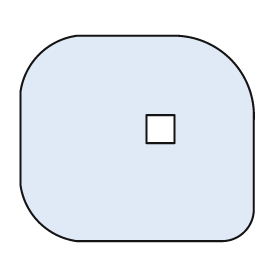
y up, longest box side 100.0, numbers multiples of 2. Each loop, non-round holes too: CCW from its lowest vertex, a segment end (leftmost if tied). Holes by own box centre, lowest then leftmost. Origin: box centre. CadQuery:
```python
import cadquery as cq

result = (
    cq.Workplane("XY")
    .moveTo(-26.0, -44.0)
    .lineTo(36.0, -44.0)
    .threePointArc((46.0, -40.0), (50.0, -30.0))
    .lineTo(50.0, 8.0)
    .threePointArc((40.0, 34.0), (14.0, 44.0))
    .lineTo(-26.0, 44.0)
    .threePointArc((-42.0, 36.0), (-50.0, 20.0))
    .lineTo(-50.0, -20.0)
    .threePointArc((-42.0, -36.0), (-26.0, -44.0))
    .close()
    .moveTo(4.0, -2.0)
    .lineTo(16.0, -2.0)
    .lineTo(16.0, 10.0)
    .lineTo(4.0, 10.0)
    .close()
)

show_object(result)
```